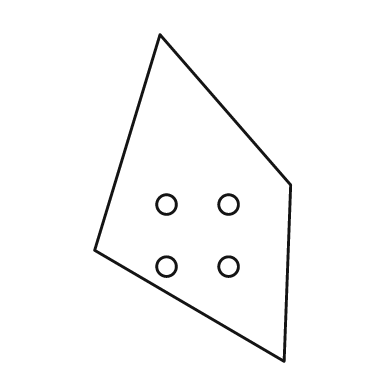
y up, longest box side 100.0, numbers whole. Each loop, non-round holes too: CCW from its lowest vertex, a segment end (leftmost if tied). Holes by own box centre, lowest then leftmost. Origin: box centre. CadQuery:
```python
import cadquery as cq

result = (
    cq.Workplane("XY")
    .moveTo(28.0, -50.0)
    .lineTo(30.0, 4.0)
    .lineTo(-10.0, 50.0)
    .lineTo(-30.0, -16.0)
    .close()
    .moveTo(-8.0, -21.0)
    .circle(3.0)
    .moveTo(11.0, -21.0)
    .circle(3.0)
    .moveTo(-8.0, -2.0)
    .circle(3.0)
    .moveTo(11.0, -2.0)
    .circle(3.0)
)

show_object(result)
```